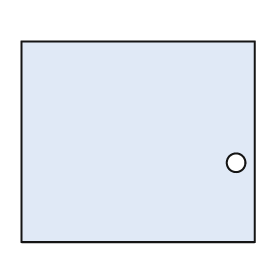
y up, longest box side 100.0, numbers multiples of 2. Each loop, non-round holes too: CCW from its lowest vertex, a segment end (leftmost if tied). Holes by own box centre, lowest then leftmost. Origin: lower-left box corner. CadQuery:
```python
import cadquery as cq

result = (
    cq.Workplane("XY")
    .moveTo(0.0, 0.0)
    .lineTo(100.0, 0.0)
    .lineTo(100.0, 86.0)
    .lineTo(0.0, 86.0)
    .close()
    .moveTo(92.0, 34.0)
    .circle(4.0)
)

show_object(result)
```